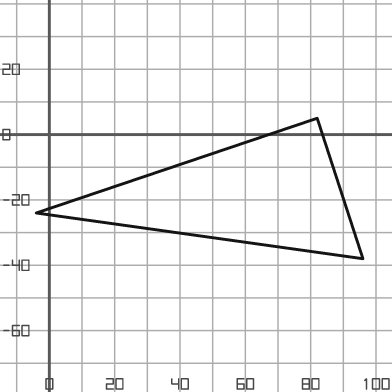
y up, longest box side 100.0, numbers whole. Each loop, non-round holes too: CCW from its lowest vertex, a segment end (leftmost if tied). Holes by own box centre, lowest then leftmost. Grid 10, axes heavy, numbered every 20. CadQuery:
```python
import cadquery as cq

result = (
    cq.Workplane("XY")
    .moveTo(96.0, -38.0)
    .lineTo(82.0, 5.0)
    .lineTo(-4.0, -24.0)
    .close()
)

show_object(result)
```